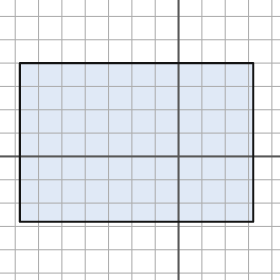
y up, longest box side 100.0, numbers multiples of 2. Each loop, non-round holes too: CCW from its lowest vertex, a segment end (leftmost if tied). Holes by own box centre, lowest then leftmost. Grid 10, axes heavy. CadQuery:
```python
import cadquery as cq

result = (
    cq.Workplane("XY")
    .moveTo(-68.0, -28.0)
    .lineTo(32.0, -28.0)
    .lineTo(32.0, 40.0)
    .lineTo(-68.0, 40.0)
    .close()
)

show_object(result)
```